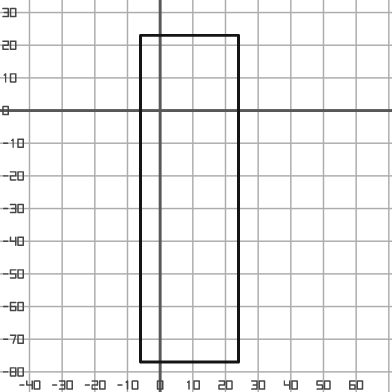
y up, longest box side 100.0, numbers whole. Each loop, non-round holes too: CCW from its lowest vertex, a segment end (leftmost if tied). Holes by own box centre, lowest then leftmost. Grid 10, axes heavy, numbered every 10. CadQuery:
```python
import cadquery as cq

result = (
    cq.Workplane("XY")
    .moveTo(-6.0, -77.0)
    .lineTo(24.0, -77.0)
    .lineTo(24.0, 23.0)
    .lineTo(-6.0, 23.0)
    .close()
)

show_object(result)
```